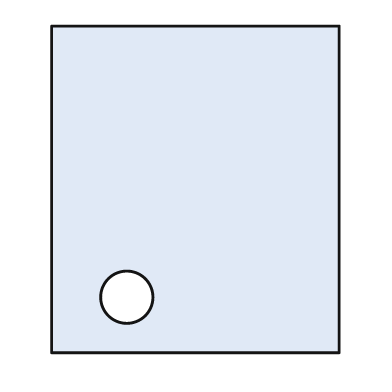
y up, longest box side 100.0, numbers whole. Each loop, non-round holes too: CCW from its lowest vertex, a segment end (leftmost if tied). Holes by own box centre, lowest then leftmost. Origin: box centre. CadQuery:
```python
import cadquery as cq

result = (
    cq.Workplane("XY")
    .moveTo(-44.0, -50.0)
    .lineTo(44.0, -50.0)
    .lineTo(44.0, 50.0)
    .lineTo(-44.0, 50.0)
    .close()
    .moveTo(-21.0, -33.0)
    .circle(8.0)
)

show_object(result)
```